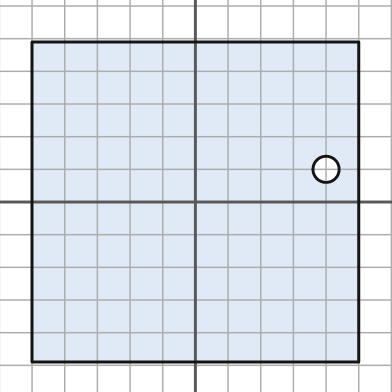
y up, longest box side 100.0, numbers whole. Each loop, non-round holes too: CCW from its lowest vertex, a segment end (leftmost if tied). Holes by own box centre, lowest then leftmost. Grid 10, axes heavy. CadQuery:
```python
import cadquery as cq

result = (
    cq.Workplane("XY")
    .moveTo(-50.0, -49.0)
    .lineTo(50.0, -49.0)
    .lineTo(50.0, 49.0)
    .lineTo(-50.0, 49.0)
    .close()
    .moveTo(40.0, 10.0)
    .circle(4.0)
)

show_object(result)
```